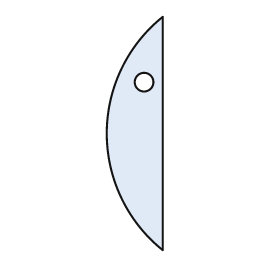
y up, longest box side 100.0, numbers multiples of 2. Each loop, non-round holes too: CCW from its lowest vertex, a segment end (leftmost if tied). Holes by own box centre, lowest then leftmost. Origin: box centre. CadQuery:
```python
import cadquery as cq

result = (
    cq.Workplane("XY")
    .moveTo(12.0, -50.0)
    .lineTo(12.0, 50.0)
    .threePointArc((-12.0, 0.0), (12.0, -50.0))
    .close()
    .moveTo(4.0, 22.0)
    .circle(4.0)
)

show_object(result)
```